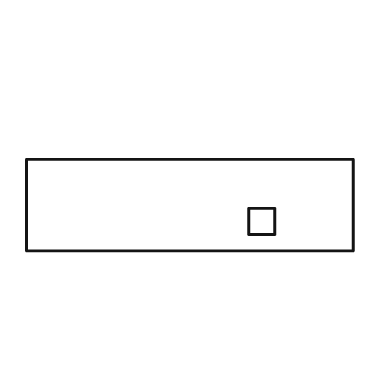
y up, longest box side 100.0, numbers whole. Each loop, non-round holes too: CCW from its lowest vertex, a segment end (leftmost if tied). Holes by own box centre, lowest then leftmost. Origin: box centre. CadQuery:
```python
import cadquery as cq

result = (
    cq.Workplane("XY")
    .moveTo(-50.0, -14.0)
    .lineTo(50.0, -14.0)
    .lineTo(50.0, 14.0)
    .lineTo(-50.0, 14.0)
    .close()
    .moveTo(18.0, -9.0)
    .lineTo(26.0, -9.0)
    .lineTo(26.0, -1.0)
    .lineTo(18.0, -1.0)
    .close()
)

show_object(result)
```